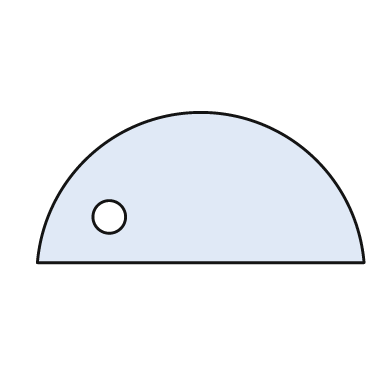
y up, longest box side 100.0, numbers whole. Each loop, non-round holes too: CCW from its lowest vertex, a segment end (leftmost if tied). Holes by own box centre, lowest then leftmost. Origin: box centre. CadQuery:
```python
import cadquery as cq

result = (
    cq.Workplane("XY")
    .moveTo(-50.0, -23.0)
    .lineTo(50.0, -23.0)
    .threePointArc((0.0, 23.0), (-50.0, -23.0))
    .close()
    .moveTo(-28.0, -9.0)
    .circle(5.0)
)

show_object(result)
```